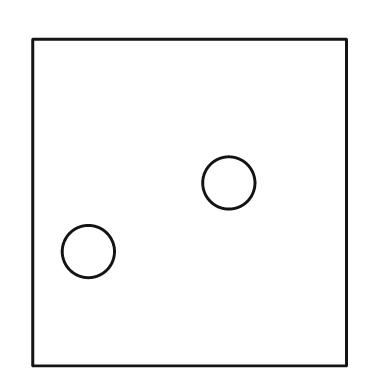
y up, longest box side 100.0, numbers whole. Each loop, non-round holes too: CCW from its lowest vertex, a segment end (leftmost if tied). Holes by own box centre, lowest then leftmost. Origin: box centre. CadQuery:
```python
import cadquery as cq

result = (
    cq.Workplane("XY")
    .moveTo(-48.0, -50.0)
    .lineTo(48.0, -50.0)
    .lineTo(48.0, 50.0)
    .lineTo(-48.0, 50.0)
    .close()
    .moveTo(-31.0, -15.0)
    .circle(8.0)
    .moveTo(12.0, 6.0)
    .circle(8.0)
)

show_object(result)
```